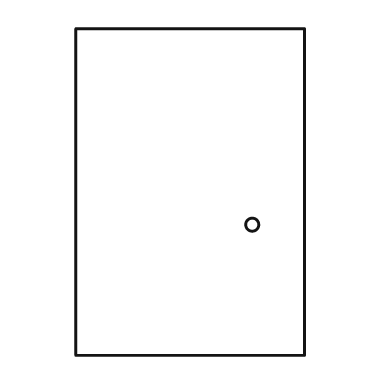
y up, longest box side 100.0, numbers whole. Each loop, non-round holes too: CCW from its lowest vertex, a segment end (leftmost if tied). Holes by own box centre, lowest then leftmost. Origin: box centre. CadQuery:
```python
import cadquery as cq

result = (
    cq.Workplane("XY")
    .moveTo(-35.0, -50.0)
    .lineTo(35.0, -50.0)
    .lineTo(35.0, 50.0)
    .lineTo(-35.0, 50.0)
    .close()
    .moveTo(19.0, -10.0)
    .circle(2.0)
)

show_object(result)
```